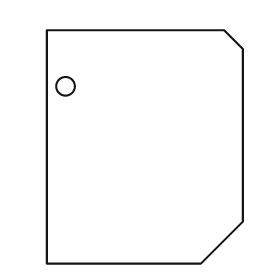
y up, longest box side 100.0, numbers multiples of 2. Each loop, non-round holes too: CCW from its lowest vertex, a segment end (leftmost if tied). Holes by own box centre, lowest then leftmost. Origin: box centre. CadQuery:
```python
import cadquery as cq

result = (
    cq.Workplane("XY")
    .moveTo(-42.0, -50.0)
    .lineTo(24.0, -50.0)
    .lineTo(42.0, -32.0)
    .lineTo(42.0, 42.0)
    .lineTo(34.0, 50.0)
    .lineTo(-42.0, 50.0)
    .close()
    .moveTo(-34.0, 26.0)
    .circle(4.0)
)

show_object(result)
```